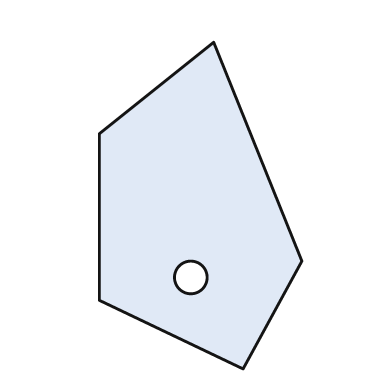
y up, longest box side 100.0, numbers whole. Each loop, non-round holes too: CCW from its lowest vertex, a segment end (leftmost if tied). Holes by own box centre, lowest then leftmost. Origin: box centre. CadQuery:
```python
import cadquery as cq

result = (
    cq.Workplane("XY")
    .moveTo(13.0, -50.0)
    .lineTo(31.0, -17.0)
    .lineTo(4.0, 50.0)
    .lineTo(-31.0, 22.0)
    .lineTo(-31.0, -29.0)
    .close()
    .moveTo(-3.0, -22.0)
    .circle(5.0)
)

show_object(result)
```